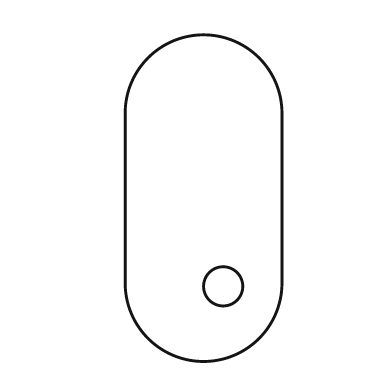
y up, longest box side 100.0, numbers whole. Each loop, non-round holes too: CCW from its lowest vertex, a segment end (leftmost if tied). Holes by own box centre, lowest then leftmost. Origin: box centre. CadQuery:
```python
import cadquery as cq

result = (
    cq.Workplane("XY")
    .moveTo(-24.0, -26.0)
    .threePointArc((0.0, -50.0), (24.0, -26.0))
    .lineTo(24.0, 26.0)
    .threePointArc((0.0, 50.0), (-24.0, 26.0))
    .close()
    .moveTo(6.0, -27.0)
    .circle(6.0)
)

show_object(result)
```